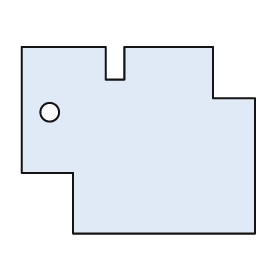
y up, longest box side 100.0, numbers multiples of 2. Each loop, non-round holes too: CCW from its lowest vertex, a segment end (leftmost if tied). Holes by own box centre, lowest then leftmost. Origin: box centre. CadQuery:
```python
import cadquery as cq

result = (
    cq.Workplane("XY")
    .moveTo(-28.0, -40.0)
    .lineTo(50.0, -40.0)
    .lineTo(50.0, 18.0)
    .lineTo(32.0, 18.0)
    .lineTo(32.0, 40.0)
    .lineTo(-6.0, 40.0)
    .lineTo(-6.0, 26.0)
    .lineTo(-14.0, 26.0)
    .lineTo(-14.0, 40.0)
    .lineTo(-50.0, 40.0)
    .lineTo(-50.0, -14.0)
    .lineTo(-28.0, -14.0)
    .close()
    .moveTo(-38.0, 12.0)
    .circle(4.0)
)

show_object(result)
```